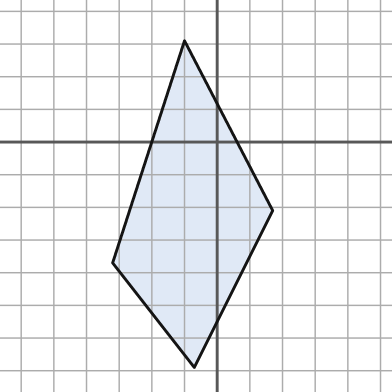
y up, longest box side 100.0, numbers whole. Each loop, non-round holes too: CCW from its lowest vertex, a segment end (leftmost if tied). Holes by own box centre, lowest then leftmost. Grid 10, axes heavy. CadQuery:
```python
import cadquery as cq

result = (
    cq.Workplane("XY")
    .moveTo(-7.0, -69.0)
    .lineTo(17.0, -21.0)
    .lineTo(-10.0, 31.0)
    .lineTo(-32.0, -37.0)
    .close()
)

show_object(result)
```